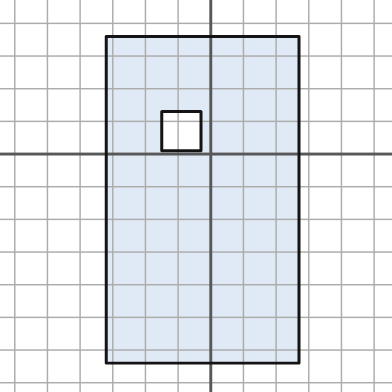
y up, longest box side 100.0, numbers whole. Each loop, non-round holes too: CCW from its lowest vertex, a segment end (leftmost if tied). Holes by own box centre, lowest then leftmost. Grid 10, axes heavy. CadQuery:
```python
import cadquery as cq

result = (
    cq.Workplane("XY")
    .moveTo(-32.0, -64.0)
    .lineTo(27.0, -64.0)
    .lineTo(27.0, 36.0)
    .lineTo(-32.0, 36.0)
    .close()
    .moveTo(-15.0, 1.0)
    .lineTo(-3.0, 1.0)
    .lineTo(-3.0, 13.0)
    .lineTo(-15.0, 13.0)
    .close()
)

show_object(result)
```